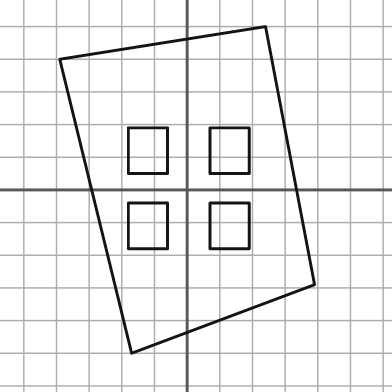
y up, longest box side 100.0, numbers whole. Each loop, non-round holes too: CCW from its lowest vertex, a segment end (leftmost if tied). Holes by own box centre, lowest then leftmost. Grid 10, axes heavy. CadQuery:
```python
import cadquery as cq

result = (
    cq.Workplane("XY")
    .moveTo(-17.0, -50.0)
    .lineTo(39.0, -29.0)
    .lineTo(24.0, 50.0)
    .lineTo(-39.0, 40.0)
    .close()
    .moveTo(-18.0, -18.0)
    .lineTo(-6.0, -18.0)
    .lineTo(-6.0, -4.0)
    .lineTo(-18.0, -4.0)
    .close()
    .moveTo(7.0, -18.0)
    .lineTo(19.0, -18.0)
    .lineTo(19.0, -4.0)
    .lineTo(7.0, -4.0)
    .close()
    .moveTo(-18.0, 5.0)
    .lineTo(-6.0, 5.0)
    .lineTo(-6.0, 19.0)
    .lineTo(-18.0, 19.0)
    .close()
    .moveTo(7.0, 5.0)
    .lineTo(19.0, 5.0)
    .lineTo(19.0, 19.0)
    .lineTo(7.0, 19.0)
    .close()
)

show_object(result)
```